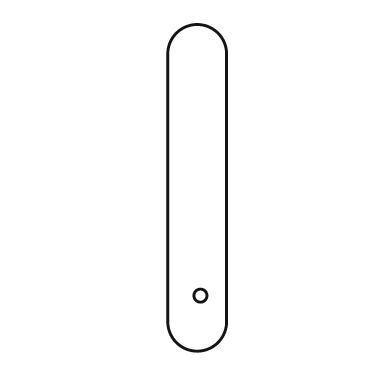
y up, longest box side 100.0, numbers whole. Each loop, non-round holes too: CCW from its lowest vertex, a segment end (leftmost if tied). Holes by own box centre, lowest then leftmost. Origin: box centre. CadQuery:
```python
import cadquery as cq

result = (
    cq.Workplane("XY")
    .moveTo(-9.0, -41.0)
    .threePointArc((0.0, -50.0), (9.0, -41.0))
    .lineTo(9.0, 41.0)
    .threePointArc((0.0, 50.0), (-9.0, 41.0))
    .close()
    .moveTo(1.0, -33.0)
    .circle(2.0)
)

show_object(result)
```